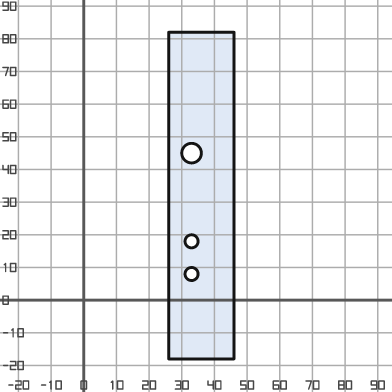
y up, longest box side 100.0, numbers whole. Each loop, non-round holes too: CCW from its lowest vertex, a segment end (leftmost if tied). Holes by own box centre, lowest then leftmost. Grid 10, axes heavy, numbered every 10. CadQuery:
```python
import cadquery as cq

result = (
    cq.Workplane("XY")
    .moveTo(26.0, -18.0)
    .lineTo(46.0, -18.0)
    .lineTo(46.0, 82.0)
    .lineTo(26.0, 82.0)
    .close()
    .moveTo(33.0, 8.0)
    .circle(2.0)
    .moveTo(33.0, 18.0)
    .circle(2.0)
    .moveTo(33.0, 45.0)
    .circle(3.0)
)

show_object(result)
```